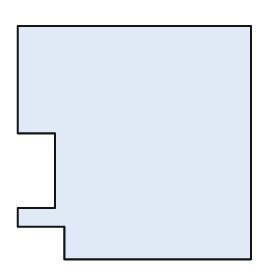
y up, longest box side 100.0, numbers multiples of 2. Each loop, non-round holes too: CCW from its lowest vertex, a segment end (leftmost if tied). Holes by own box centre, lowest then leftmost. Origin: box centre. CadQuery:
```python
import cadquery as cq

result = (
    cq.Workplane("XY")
    .moveTo(-30.0, -50.0)
    .lineTo(50.0, -50.0)
    .lineTo(50.0, 50.0)
    .lineTo(-50.0, 50.0)
    .lineTo(-50.0, 4.0)
    .lineTo(-34.0, 4.0)
    .lineTo(-34.0, -28.0)
    .lineTo(-50.0, -28.0)
    .lineTo(-50.0, -36.0)
    .lineTo(-30.0, -36.0)
    .close()
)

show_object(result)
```